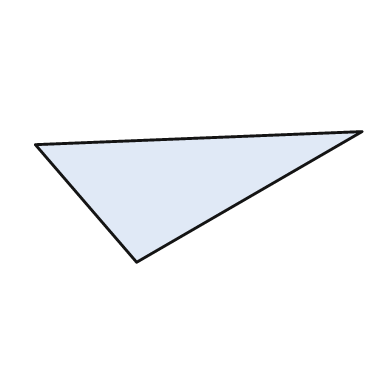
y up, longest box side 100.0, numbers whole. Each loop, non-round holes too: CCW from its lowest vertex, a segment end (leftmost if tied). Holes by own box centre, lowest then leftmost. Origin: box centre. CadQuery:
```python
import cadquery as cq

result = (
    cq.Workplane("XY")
    .moveTo(-19.0, -20.0)
    .lineTo(50.0, 20.0)
    .lineTo(-50.0, 16.0)
    .close()
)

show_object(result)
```